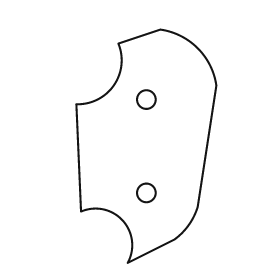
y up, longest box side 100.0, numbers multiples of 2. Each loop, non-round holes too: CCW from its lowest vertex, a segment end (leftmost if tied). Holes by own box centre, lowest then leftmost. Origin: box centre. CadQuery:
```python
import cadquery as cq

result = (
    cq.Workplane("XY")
    .moveTo(-8.0, -50.0)
    .lineTo(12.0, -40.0)
    .threePointArc((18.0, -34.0), (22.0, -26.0))
    .lineTo(30.0, 26.0)
    .threePointArc((22.0, 42.0), (6.0, 50.0))
    .lineTo(-12.0, 44.0)
    .threePointArc((-14.0, 26.0), (-30.0, 18.0))
    .lineTo(-28.0, -28.0)
    .threePointArc((-10.0, -32.0), (-8.0, -50.0))
    .close()
    .moveTo(0.0, -20.0)
    .circle(4.0)
    .moveTo(0.0, 20.0)
    .circle(4.0)
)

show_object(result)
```